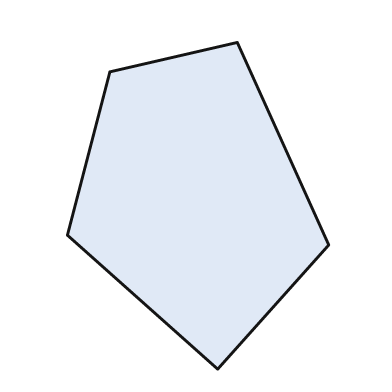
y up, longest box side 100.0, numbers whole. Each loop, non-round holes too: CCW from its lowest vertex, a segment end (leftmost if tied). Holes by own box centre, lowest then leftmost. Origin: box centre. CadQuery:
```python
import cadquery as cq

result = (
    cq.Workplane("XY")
    .moveTo(6.0, -50.0)
    .lineTo(40.0, -12.0)
    .lineTo(12.0, 50.0)
    .lineTo(-27.0, 41.0)
    .lineTo(-40.0, -9.0)
    .close()
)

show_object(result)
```